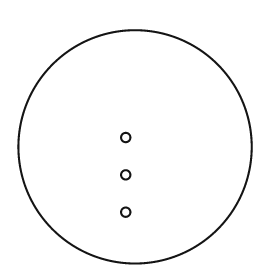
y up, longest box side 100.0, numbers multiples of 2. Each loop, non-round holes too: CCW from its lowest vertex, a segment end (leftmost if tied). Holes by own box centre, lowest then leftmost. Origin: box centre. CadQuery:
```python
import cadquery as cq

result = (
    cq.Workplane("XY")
    .moveTo(0.0, 0.0)
    .circle(50.0)
    .moveTo(-4.0, -28.0)
    .circle(2.0)
    .moveTo(-4.0, -12.0)
    .circle(2.0)
    .moveTo(-4.0, 4.0)
    .circle(2.0)
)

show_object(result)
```